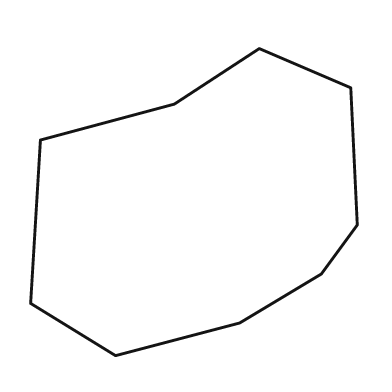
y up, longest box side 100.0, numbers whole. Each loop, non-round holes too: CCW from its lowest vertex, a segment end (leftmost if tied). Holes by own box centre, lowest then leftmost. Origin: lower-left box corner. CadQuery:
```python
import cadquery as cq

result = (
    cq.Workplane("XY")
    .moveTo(26.0, 0.0)
    .lineTo(64.0, 10.0)
    .lineTo(89.0, 25.0)
    .lineTo(100.0, 40.0)
    .lineTo(98.0, 82.0)
    .lineTo(70.0, 94.0)
    .lineTo(44.0, 77.0)
    .lineTo(3.0, 66.0)
    .lineTo(0.0, 16.0)
    .close()
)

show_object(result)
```